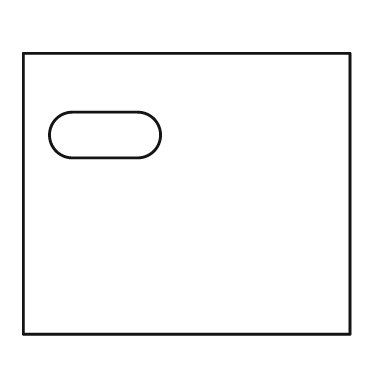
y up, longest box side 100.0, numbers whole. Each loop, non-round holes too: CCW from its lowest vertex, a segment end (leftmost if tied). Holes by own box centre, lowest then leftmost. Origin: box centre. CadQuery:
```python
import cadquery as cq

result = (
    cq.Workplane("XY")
    .moveTo(-50.0, -43.0)
    .lineTo(50.0, -43.0)
    .lineTo(50.0, 43.0)
    .lineTo(-50.0, 43.0)
    .close()
    .moveTo(-35.0, 11.0)
    .lineTo(-15.0, 11.0)
    .threePointArc((-8.0, 18.0), (-15.0, 25.0))
    .lineTo(-35.0, 25.0)
    .threePointArc((-42.0, 18.0), (-35.0, 11.0))
    .close()
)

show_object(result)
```